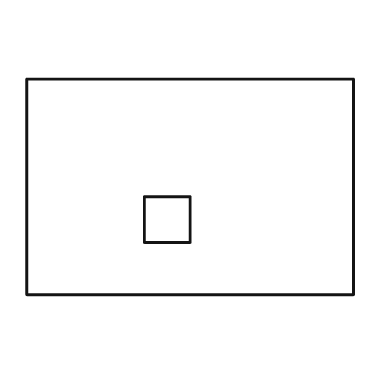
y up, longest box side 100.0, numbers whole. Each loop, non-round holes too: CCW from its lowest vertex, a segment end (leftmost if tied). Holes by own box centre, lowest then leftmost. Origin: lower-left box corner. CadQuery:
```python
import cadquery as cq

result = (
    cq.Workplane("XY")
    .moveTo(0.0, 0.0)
    .lineTo(100.0, 0.0)
    .lineTo(100.0, 66.0)
    .lineTo(0.0, 66.0)
    .close()
    .moveTo(36.0, 16.0)
    .lineTo(50.0, 16.0)
    .lineTo(50.0, 30.0)
    .lineTo(36.0, 30.0)
    .close()
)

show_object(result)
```